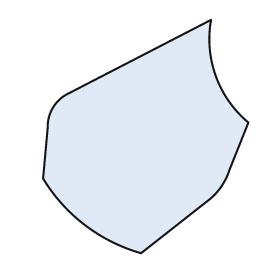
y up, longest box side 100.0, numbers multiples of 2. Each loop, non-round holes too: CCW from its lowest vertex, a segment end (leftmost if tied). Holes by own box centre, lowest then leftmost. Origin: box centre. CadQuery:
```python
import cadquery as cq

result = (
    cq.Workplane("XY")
    .moveTo(-2.0, -50.0)
    .lineTo(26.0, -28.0)
    .threePointArc((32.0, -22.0), (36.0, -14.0))
    .lineTo(44.0, 6.0)
    .threePointArc((30.0, 26.0), (28.0, 50.0))
    .lineTo(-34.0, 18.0)
    .threePointArc((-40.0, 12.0), (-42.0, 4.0))
    .lineTo(-44.0, -18.0)
    .threePointArc((-26.0, -38.0), (-2.0, -50.0))
    .close()
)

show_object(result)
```